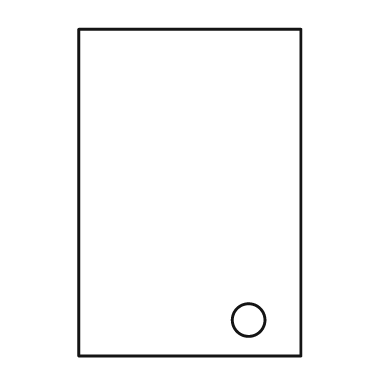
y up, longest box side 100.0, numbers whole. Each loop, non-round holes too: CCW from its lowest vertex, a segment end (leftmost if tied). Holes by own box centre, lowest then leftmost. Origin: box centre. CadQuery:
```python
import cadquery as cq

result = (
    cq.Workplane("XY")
    .moveTo(-34.0, -50.0)
    .lineTo(34.0, -50.0)
    .lineTo(34.0, 50.0)
    .lineTo(-34.0, 50.0)
    .close()
    .moveTo(18.0, -39.0)
    .circle(5.0)
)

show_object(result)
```